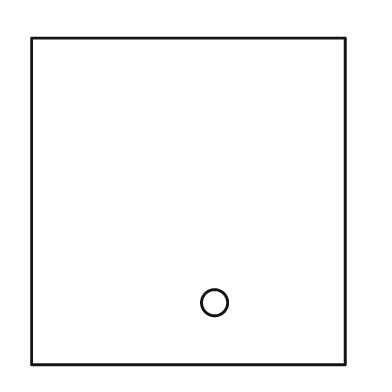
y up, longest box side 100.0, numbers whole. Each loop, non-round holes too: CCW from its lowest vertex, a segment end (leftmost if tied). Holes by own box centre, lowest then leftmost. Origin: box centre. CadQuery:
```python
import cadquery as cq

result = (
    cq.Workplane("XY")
    .moveTo(-48.0, -50.0)
    .lineTo(48.0, -50.0)
    .lineTo(48.0, 50.0)
    .lineTo(-48.0, 50.0)
    .close()
    .moveTo(8.0, -31.0)
    .circle(4.0)
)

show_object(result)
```